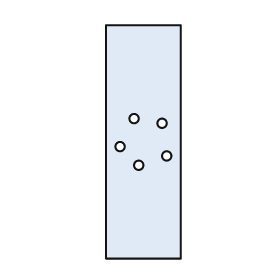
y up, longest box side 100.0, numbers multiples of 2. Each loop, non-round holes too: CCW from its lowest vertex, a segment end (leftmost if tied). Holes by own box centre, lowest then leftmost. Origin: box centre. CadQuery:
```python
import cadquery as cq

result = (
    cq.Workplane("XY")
    .moveTo(-16.0, -50.0)
    .lineTo(16.0, -50.0)
    .lineTo(16.0, 50.0)
    .lineTo(-16.0, 50.0)
    .close()
    .moveTo(-2.0, -10.0)
    .circle(2.0)
    .moveTo(10.0, -6.0)
    .circle(2.0)
    .moveTo(-10.0, -2.0)
    .circle(2.0)
    .moveTo(8.0, 8.0)
    .circle(2.0)
    .moveTo(-4.0, 10.0)
    .circle(2.0)
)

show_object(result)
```